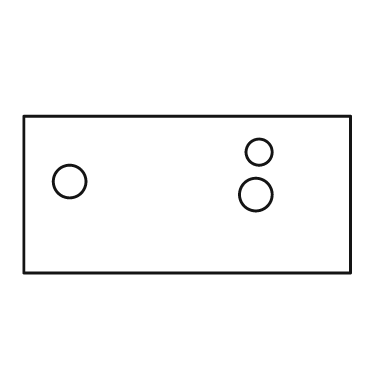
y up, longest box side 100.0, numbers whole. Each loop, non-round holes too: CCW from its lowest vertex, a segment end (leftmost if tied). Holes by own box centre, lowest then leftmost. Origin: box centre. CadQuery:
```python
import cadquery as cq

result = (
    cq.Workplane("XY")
    .moveTo(-50.0, -24.0)
    .lineTo(50.0, -24.0)
    .lineTo(50.0, 24.0)
    .lineTo(-50.0, 24.0)
    .close()
    .moveTo(21.0, 0.0)
    .circle(5.0)
    .moveTo(-36.0, 4.0)
    .circle(5.0)
    .moveTo(22.0, 13.0)
    .circle(4.0)
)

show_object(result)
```